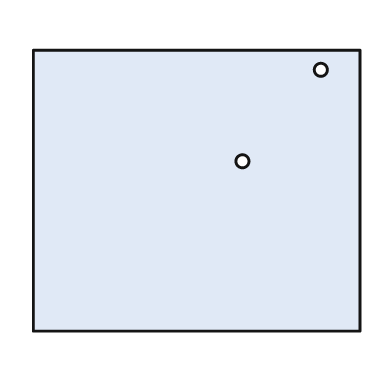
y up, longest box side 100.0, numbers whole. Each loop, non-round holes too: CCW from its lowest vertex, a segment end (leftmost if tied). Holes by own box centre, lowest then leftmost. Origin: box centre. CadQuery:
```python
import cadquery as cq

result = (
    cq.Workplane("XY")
    .moveTo(-50.0, -43.0)
    .lineTo(50.0, -43.0)
    .lineTo(50.0, 43.0)
    .lineTo(-50.0, 43.0)
    .close()
    .moveTo(14.0, 9.0)
    .circle(2.0)
    .moveTo(38.0, 37.0)
    .circle(2.0)
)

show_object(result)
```